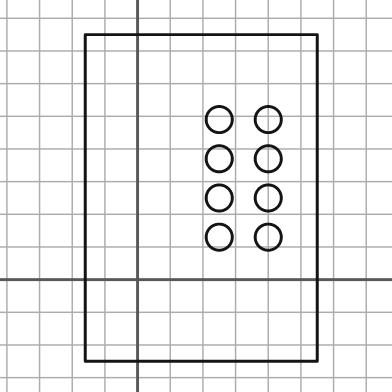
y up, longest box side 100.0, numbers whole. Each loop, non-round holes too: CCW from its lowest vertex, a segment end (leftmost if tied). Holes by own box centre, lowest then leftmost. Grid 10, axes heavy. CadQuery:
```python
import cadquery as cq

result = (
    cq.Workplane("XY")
    .moveTo(-16.0, -25.0)
    .lineTo(55.0, -25.0)
    .lineTo(55.0, 75.0)
    .lineTo(-16.0, 75.0)
    .close()
    .moveTo(25.0, 13.0)
    .circle(4.0)
    .moveTo(40.0, 13.0)
    .circle(4.0)
    .moveTo(25.0, 25.0)
    .circle(4.0)
    .moveTo(40.0, 25.0)
    .circle(4.0)
    .moveTo(25.0, 37.0)
    .circle(4.0)
    .moveTo(40.0, 37.0)
    .circle(4.0)
    .moveTo(25.0, 49.0)
    .circle(4.0)
    .moveTo(40.0, 49.0)
    .circle(4.0)
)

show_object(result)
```